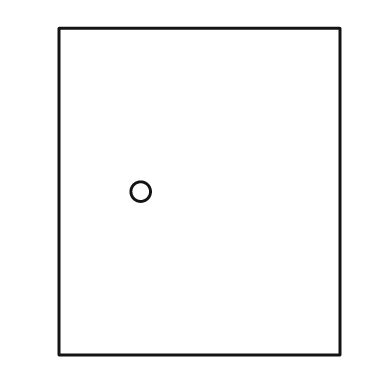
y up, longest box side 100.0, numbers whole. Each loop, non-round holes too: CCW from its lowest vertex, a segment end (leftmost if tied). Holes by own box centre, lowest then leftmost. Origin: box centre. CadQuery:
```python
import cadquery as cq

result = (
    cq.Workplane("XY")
    .moveTo(-43.0, -50.0)
    .lineTo(43.0, -50.0)
    .lineTo(43.0, 50.0)
    .lineTo(-43.0, 50.0)
    .close()
    .moveTo(-18.0, 0.0)
    .circle(3.0)
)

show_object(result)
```